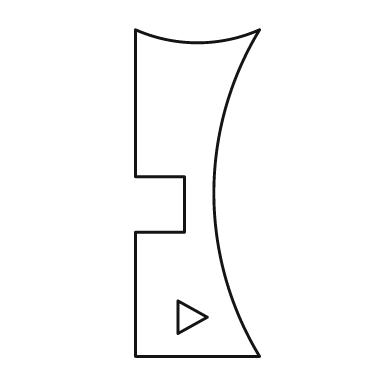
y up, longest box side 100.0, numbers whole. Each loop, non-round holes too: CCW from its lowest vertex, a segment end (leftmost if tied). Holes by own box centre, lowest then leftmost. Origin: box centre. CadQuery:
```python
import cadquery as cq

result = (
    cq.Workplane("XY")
    .moveTo(-19.0, -50.0)
    .lineTo(19.0, -50.0)
    .threePointArc((5.0, 0.0), (19.0, 50.0))
    .threePointArc((0.0, 46.0), (-19.0, 50.0))
    .lineTo(-19.0, 5.0)
    .lineTo(-4.0, 5.0)
    .lineTo(-4.0, -12.0)
    .lineTo(-19.0, -12.0)
    .close()
    .moveTo(-6.0, -43.0)
    .lineTo(3.0, -38.0)
    .lineTo(-6.0, -33.0)
    .close()
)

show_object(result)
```